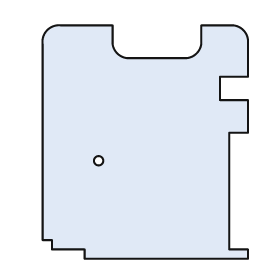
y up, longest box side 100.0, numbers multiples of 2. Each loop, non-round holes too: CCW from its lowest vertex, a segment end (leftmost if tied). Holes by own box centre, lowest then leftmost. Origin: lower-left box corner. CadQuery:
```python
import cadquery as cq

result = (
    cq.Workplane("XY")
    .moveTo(18.0, 0.0)
    .lineTo(88.0, 0.0)
    .lineTo(88.0, 4.0)
    .lineTo(80.0, 4.0)
    .lineTo(80.0, 54.0)
    .lineTo(88.0, 54.0)
    .lineTo(88.0, 68.0)
    .lineTo(76.0, 68.0)
    .lineTo(76.0, 78.0)
    .lineTo(88.0, 78.0)
    .lineTo(88.0, 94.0)
    .threePointArc((86.0, 98.0), (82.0, 100.0))
    .lineTo(68.0, 100.0)
    .lineTo(68.0, 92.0)
    .threePointArc((66.0, 88.0), (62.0, 86.0))
    .lineTo(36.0, 86.0)
    .threePointArc((32.0, 88.0), (30.0, 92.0))
    .lineTo(30.0, 100.0)
    .lineTo(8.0, 100.0)
    .threePointArc((2.0, 98.0), (0.0, 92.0))
    .lineTo(0.0, 8.0)
    .lineTo(4.0, 8.0)
    .lineTo(4.0, 4.0)
    .lineTo(18.0, 4.0)
    .close()
    .moveTo(24.0, 42.0)
    .circle(2.0)
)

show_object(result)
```